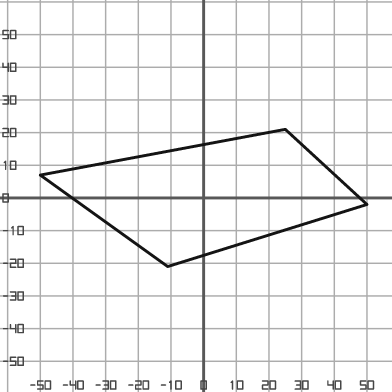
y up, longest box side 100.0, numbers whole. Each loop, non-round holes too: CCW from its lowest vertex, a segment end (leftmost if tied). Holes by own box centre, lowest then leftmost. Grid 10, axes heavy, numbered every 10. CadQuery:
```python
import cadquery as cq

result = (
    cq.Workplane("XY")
    .moveTo(-11.0, -21.0)
    .lineTo(50.0, -2.0)
    .lineTo(25.0, 21.0)
    .lineTo(-50.0, 7.0)
    .close()
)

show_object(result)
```